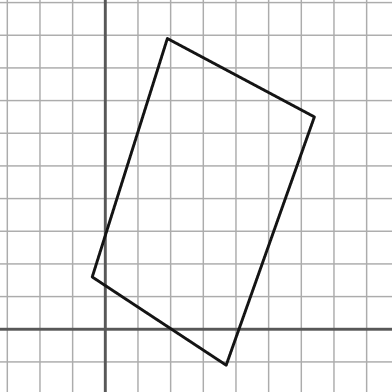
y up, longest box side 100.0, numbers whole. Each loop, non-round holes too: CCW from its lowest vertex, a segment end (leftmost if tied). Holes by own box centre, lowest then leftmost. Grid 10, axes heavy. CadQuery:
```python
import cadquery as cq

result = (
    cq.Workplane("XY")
    .moveTo(37.0, -11.0)
    .lineTo(64.0, 65.0)
    .lineTo(19.0, 89.0)
    .lineTo(-4.0, 16.0)
    .close()
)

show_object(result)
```